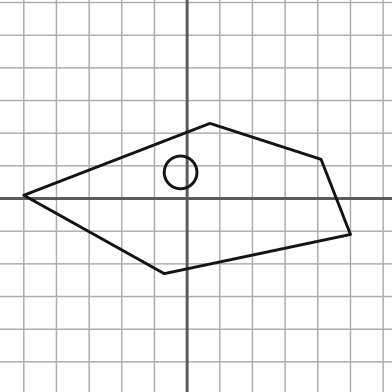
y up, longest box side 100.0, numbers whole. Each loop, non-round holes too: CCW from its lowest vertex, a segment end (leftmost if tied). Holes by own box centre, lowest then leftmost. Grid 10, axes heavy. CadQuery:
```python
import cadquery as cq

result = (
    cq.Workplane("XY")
    .moveTo(-7.0, -23.0)
    .lineTo(50.0, -11.0)
    .lineTo(41.0, 12.0)
    .lineTo(7.0, 23.0)
    .lineTo(-50.0, 1.0)
    .close()
    .moveTo(-2.0, 8.0)
    .circle(5.0)
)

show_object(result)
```